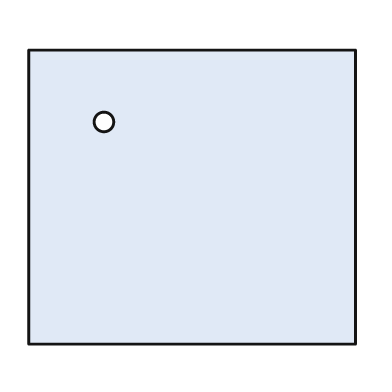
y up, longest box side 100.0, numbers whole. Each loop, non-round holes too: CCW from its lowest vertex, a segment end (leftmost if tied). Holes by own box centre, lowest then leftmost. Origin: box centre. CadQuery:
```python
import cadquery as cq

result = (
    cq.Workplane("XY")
    .moveTo(-50.0, -45.0)
    .lineTo(50.0, -45.0)
    .lineTo(50.0, 45.0)
    .lineTo(-50.0, 45.0)
    .close()
    .moveTo(-27.0, 23.0)
    .circle(3.0)
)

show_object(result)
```